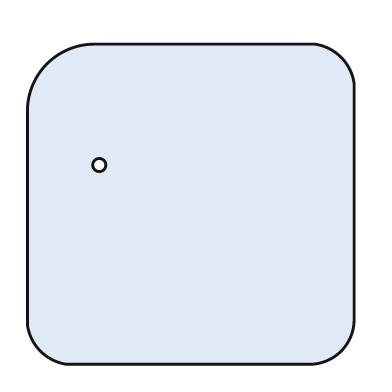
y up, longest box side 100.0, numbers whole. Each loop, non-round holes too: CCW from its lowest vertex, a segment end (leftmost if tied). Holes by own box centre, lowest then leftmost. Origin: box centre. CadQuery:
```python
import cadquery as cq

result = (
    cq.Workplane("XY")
    .moveTo(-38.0, -49.0)
    .lineTo(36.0, -49.0)
    .threePointArc((46.0, -45.0), (50.0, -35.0))
    .lineTo(50.0, 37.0)
    .threePointArc((46.0, 45.0), (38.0, 49.0))
    .lineTo(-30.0, 49.0)
    .threePointArc((-44.0, 43.0), (-50.0, 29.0))
    .lineTo(-50.0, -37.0)
    .threePointArc((-46.0, -45.0), (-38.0, -49.0))
    .close()
    .moveTo(-28.0, 12.0)
    .circle(2.0)
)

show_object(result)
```